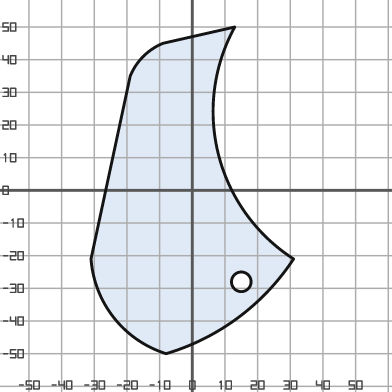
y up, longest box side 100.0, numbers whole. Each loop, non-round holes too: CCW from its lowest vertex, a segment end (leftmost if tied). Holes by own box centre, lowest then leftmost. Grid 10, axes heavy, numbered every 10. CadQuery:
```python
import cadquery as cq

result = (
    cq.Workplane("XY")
    .moveTo(-8.0, -50.0)
    .threePointArc((14.0, -39.0), (31.0, -21.0))
    .threePointArc((8.0, 11.0), (13.0, 50.0))
    .lineTo(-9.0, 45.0)
    .threePointArc((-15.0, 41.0), (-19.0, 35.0))
    .lineTo(-31.0, -21.0)
    .threePointArc((-24.0, -39.0), (-8.0, -50.0))
    .close()
    .moveTo(15.0, -28.0)
    .circle(3.0)
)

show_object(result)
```